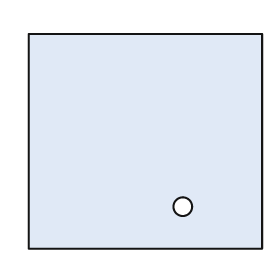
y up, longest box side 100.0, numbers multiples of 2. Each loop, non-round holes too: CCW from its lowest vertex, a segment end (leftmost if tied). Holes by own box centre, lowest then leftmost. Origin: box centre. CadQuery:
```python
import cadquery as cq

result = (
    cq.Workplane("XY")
    .moveTo(-50.0, -46.0)
    .lineTo(50.0, -46.0)
    .lineTo(50.0, 46.0)
    .lineTo(-50.0, 46.0)
    .close()
    .moveTo(16.0, -28.0)
    .circle(4.0)
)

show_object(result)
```